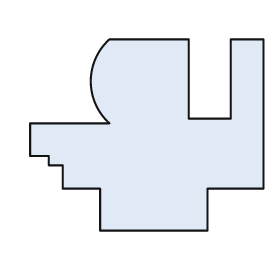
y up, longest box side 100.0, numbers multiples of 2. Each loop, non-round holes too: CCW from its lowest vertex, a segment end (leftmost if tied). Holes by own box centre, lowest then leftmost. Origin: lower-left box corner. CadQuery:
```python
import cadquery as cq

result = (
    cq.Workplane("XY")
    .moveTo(30.0, 0.0)
    .lineTo(76.0, 0.0)
    .lineTo(76.0, 18.0)
    .lineTo(100.0, 18.0)
    .lineTo(100.0, 82.0)
    .lineTo(86.0, 82.0)
    .lineTo(86.0, 48.0)
    .lineTo(68.0, 48.0)
    .lineTo(68.0, 82.0)
    .lineTo(34.0, 82.0)
    .threePointArc((26.0, 64.0), (34.0, 46.0))
    .lineTo(0.0, 46.0)
    .lineTo(0.0, 32.0)
    .lineTo(8.0, 32.0)
    .lineTo(8.0, 28.0)
    .lineTo(14.0, 28.0)
    .lineTo(14.0, 18.0)
    .lineTo(30.0, 18.0)
    .close()
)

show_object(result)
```